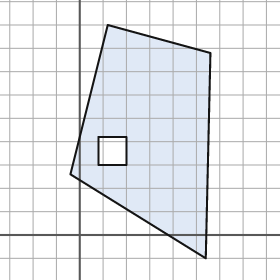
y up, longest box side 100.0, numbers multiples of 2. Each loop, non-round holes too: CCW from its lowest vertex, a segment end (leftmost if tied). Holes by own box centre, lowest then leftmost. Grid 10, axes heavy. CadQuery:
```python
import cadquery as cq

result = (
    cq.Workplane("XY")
    .moveTo(54.0, -10.0)
    .lineTo(56.0, 78.0)
    .lineTo(12.0, 90.0)
    .lineTo(-4.0, 26.0)
    .close()
    .moveTo(8.0, 30.0)
    .lineTo(20.0, 30.0)
    .lineTo(20.0, 42.0)
    .lineTo(8.0, 42.0)
    .close()
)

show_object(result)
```